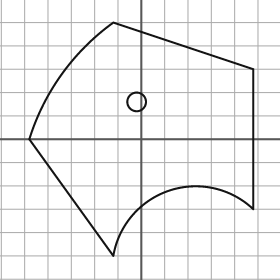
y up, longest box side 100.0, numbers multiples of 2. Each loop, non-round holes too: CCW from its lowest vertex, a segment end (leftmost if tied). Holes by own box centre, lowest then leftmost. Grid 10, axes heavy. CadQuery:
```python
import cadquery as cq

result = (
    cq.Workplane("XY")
    .moveTo(-12.0, -50.0)
    .threePointArc((12.0, -22.0), (48.0, -30.0))
    .lineTo(48.0, 30.0)
    .lineTo(-12.0, 50.0)
    .threePointArc((-34.0, 28.0), (-48.0, 0.0))
    .close()
    .moveTo(-2.0, 16.0)
    .circle(4.0)
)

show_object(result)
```